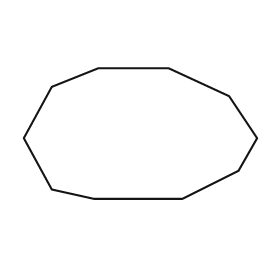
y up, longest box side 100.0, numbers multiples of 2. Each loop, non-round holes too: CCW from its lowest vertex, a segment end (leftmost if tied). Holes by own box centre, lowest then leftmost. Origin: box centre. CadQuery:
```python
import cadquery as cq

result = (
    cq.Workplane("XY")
    .moveTo(-20.0, -28.0)
    .lineTo(18.0, -28.0)
    .lineTo(42.0, -16.0)
    .lineTo(50.0, -2.0)
    .lineTo(38.0, 16.0)
    .lineTo(12.0, 28.0)
    .lineTo(-18.0, 28.0)
    .lineTo(-38.0, 20.0)
    .lineTo(-50.0, -2.0)
    .lineTo(-38.0, -24.0)
    .close()
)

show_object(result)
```